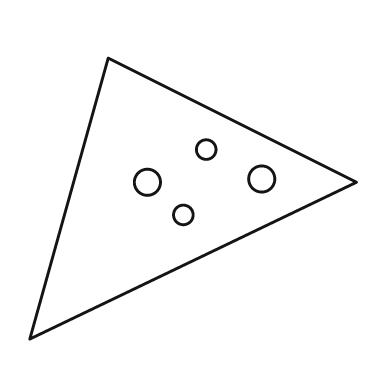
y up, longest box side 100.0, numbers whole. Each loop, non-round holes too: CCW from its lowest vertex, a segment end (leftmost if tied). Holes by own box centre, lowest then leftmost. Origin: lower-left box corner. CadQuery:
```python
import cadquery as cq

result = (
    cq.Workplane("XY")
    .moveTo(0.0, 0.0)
    .lineTo(100.0, 48.0)
    .lineTo(24.0, 86.0)
    .close()
    .moveTo(47.0, 38.0)
    .circle(3.0)
    .moveTo(36.0, 48.0)
    .circle(4.0)
    .moveTo(71.0, 49.0)
    .circle(4.0)
    .moveTo(54.0, 58.0)
    .circle(3.0)
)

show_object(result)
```